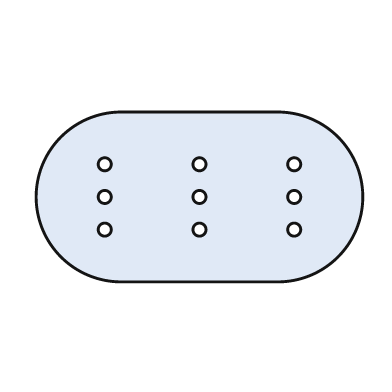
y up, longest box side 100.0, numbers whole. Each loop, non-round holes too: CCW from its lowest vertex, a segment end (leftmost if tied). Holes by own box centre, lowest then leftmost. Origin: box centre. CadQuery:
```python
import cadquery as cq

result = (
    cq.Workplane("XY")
    .moveTo(-24.0, -26.0)
    .lineTo(24.0, -26.0)
    .threePointArc((50.0, 0.0), (24.0, 26.0))
    .lineTo(-24.0, 26.0)
    .threePointArc((-50.0, 0.0), (-24.0, -26.0))
    .close()
    .moveTo(-29.0, -10.0)
    .circle(2.0)
    .moveTo(0.0, -10.0)
    .circle(2.0)
    .moveTo(29.0, -10.0)
    .circle(2.0)
    .moveTo(-29.0, 0.0)
    .circle(2.0)
    .moveTo(0.0, 0.0)
    .circle(2.0)
    .moveTo(29.0, 0.0)
    .circle(2.0)
    .moveTo(-29.0, 10.0)
    .circle(2.0)
    .moveTo(0.0, 10.0)
    .circle(2.0)
    .moveTo(29.0, 10.0)
    .circle(2.0)
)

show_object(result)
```